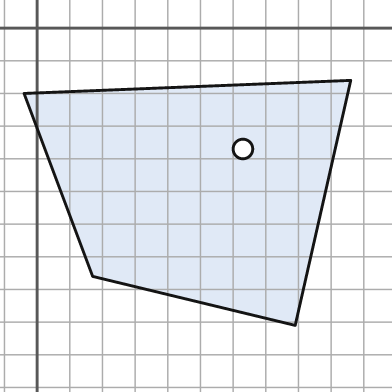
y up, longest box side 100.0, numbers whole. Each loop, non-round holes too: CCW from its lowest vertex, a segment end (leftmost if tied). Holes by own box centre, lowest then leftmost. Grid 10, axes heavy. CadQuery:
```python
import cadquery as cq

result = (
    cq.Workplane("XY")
    .moveTo(79.0, -91.0)
    .lineTo(96.0, -16.0)
    .lineTo(-4.0, -20.0)
    .lineTo(17.0, -76.0)
    .close()
    .moveTo(63.0, -37.0)
    .circle(3.0)
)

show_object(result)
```